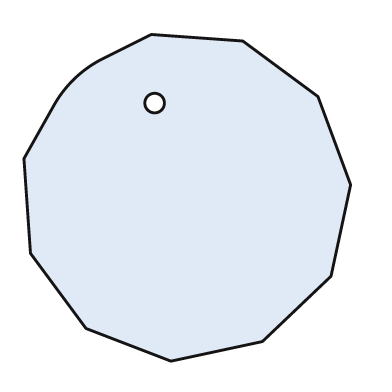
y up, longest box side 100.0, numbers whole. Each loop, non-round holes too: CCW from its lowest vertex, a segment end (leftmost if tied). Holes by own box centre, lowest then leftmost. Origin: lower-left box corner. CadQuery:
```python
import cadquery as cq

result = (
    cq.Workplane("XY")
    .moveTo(45.0, 0.0)
    .lineTo(73.0, 6.0)
    .lineTo(94.0, 26.0)
    .lineTo(100.0, 54.0)
    .lineTo(90.0, 81.0)
    .lineTo(67.0, 98.0)
    .lineTo(39.0, 100.0)
    .lineTo(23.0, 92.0)
    .threePointArc((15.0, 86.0), (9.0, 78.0))
    .lineTo(0.0, 62.0)
    .lineTo(2.0, 33.0)
    .lineTo(19.0, 10.0)
    .close()
    .moveTo(40.0, 79.0)
    .circle(3.0)
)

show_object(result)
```